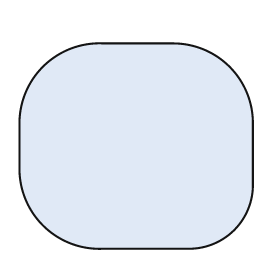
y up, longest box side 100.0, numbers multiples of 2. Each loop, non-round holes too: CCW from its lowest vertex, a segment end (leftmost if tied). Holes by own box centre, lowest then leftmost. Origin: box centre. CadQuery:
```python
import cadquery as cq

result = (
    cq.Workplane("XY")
    .moveTo(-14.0, -44.0)
    .lineTo(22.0, -44.0)
    .threePointArc((42.0, -36.0), (50.0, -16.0))
    .lineTo(50.0, 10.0)
    .threePointArc((40.0, 34.0), (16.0, 44.0))
    .lineTo(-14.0, 44.0)
    .threePointArc((-40.0, 34.0), (-50.0, 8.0))
    .lineTo(-50.0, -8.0)
    .threePointArc((-40.0, -34.0), (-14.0, -44.0))
    .close()
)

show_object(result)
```